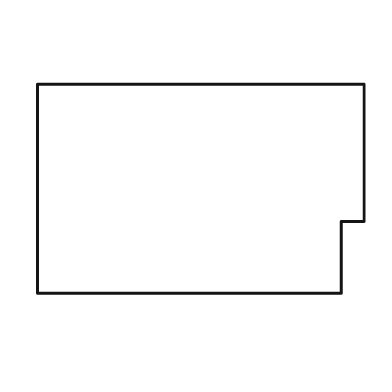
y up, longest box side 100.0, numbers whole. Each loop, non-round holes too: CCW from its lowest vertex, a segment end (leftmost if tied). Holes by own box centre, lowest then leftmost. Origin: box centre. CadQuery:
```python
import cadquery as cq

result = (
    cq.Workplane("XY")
    .moveTo(-50.0, -32.0)
    .lineTo(43.0, -32.0)
    .lineTo(43.0, -10.0)
    .lineTo(50.0, -10.0)
    .lineTo(50.0, 32.0)
    .lineTo(-50.0, 32.0)
    .close()
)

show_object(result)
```